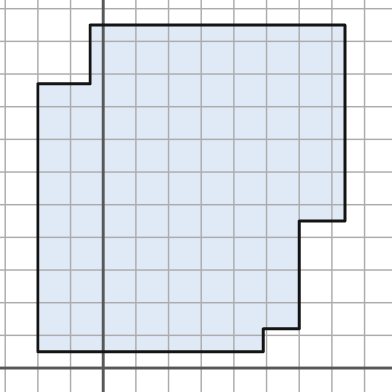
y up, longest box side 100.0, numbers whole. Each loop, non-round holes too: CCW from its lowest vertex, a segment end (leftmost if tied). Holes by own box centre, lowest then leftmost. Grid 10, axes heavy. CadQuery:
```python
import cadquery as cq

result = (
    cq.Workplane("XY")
    .moveTo(-20.0, 5.0)
    .lineTo(49.0, 5.0)
    .lineTo(49.0, 12.0)
    .lineTo(60.0, 12.0)
    .lineTo(60.0, 45.0)
    .lineTo(74.0, 45.0)
    .lineTo(74.0, 105.0)
    .lineTo(-4.0, 105.0)
    .lineTo(-4.0, 87.0)
    .lineTo(-20.0, 87.0)
    .close()
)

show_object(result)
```